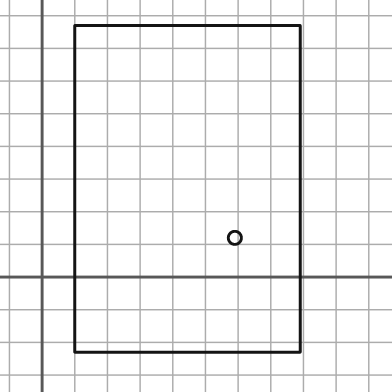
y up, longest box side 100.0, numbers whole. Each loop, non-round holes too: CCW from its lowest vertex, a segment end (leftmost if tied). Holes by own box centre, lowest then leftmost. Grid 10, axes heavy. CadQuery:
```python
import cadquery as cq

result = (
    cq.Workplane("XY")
    .moveTo(10.0, -23.0)
    .lineTo(79.0, -23.0)
    .lineTo(79.0, 77.0)
    .lineTo(10.0, 77.0)
    .close()
    .moveTo(59.0, 12.0)
    .circle(2.0)
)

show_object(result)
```